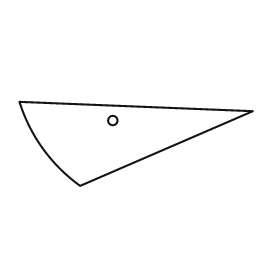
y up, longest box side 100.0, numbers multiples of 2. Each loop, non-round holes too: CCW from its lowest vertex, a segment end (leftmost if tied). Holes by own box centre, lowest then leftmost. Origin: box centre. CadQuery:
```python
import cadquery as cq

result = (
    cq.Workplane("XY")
    .moveTo(-24.0, -18.0)
    .lineTo(50.0, 14.0)
    .lineTo(-50.0, 18.0)
    .threePointArc((-40.0, -2.0), (-24.0, -18.0))
    .close()
    .moveTo(-10.0, 10.0)
    .circle(2.0)
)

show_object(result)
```